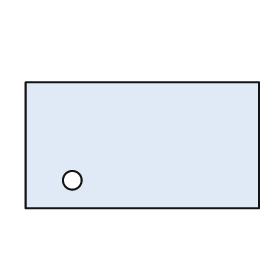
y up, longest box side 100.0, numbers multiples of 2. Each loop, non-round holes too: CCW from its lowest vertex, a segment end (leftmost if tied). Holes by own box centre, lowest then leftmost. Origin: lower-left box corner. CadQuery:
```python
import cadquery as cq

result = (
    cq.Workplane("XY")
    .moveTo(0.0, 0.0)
    .lineTo(100.0, 0.0)
    .lineTo(100.0, 54.0)
    .lineTo(0.0, 54.0)
    .close()
    .moveTo(20.0, 12.0)
    .circle(4.0)
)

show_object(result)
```